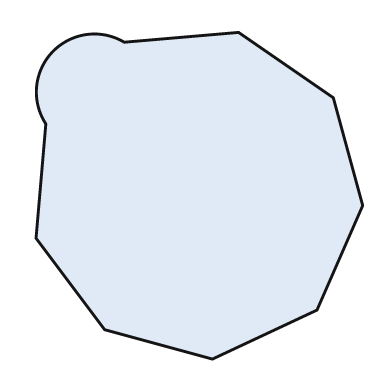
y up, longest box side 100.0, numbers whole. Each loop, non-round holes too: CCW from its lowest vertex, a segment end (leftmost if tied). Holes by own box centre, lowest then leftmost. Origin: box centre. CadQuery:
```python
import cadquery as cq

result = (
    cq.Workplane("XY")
    .moveTo(4.0, -50.0)
    .lineTo(36.0, -35.0)
    .lineTo(50.0, -3.0)
    .lineTo(41.0, 30.0)
    .lineTo(12.0, 50.0)
    .lineTo(-23.0, 47.0)
    .threePointArc((-45.0, 44.0), (-47.0, 22.0))
    .lineTo(-50.0, -13.0)
    .lineTo(-29.0, -41.0)
    .close()
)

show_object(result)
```